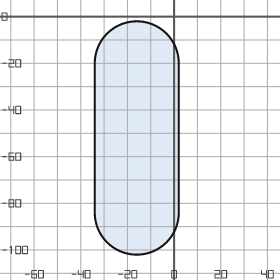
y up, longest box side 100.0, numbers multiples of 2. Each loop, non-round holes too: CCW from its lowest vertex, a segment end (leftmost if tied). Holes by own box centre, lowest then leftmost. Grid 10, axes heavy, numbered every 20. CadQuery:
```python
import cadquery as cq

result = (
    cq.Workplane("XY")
    .moveTo(-34.0, -84.0)
    .threePointArc((-16.0, -102.0), (2.0, -84.0))
    .lineTo(2.0, -20.0)
    .threePointArc((-16.0, -2.0), (-34.0, -20.0))
    .close()
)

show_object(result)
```